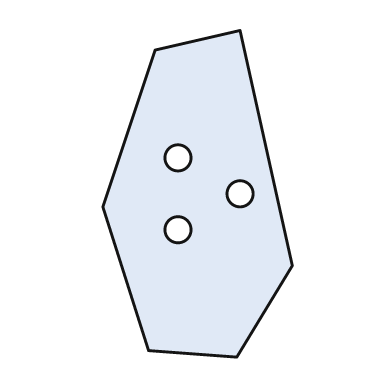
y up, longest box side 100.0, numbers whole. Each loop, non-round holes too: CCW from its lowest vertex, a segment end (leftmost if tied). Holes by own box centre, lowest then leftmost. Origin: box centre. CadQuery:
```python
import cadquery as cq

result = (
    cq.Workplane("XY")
    .moveTo(12.0, -50.0)
    .lineTo(29.0, -22.0)
    .lineTo(13.0, 50.0)
    .lineTo(-13.0, 44.0)
    .lineTo(-29.0, -4.0)
    .lineTo(-15.0, -48.0)
    .close()
    .moveTo(-6.0, -11.0)
    .circle(4.0)
    .moveTo(13.0, 0.0)
    .circle(4.0)
    .moveTo(-6.0, 11.0)
    .circle(4.0)
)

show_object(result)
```